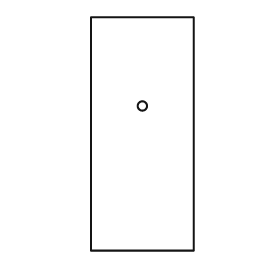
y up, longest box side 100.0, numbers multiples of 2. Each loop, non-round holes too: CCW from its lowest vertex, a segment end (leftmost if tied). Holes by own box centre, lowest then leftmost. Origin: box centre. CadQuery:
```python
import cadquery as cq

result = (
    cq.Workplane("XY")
    .moveTo(-22.0, -50.0)
    .lineTo(22.0, -50.0)
    .lineTo(22.0, 50.0)
    .lineTo(-22.0, 50.0)
    .close()
    .moveTo(0.0, 12.0)
    .circle(2.0)
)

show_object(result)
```